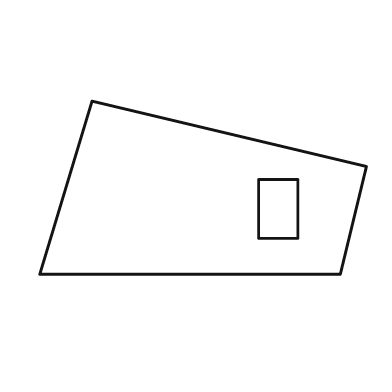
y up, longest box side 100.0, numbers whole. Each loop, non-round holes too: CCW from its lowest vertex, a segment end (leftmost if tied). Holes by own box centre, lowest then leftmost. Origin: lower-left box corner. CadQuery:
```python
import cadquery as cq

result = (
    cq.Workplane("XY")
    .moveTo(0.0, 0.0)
    .lineTo(92.0, 0.0)
    .lineTo(100.0, 33.0)
    .lineTo(16.0, 53.0)
    .close()
    .moveTo(67.0, 11.0)
    .lineTo(79.0, 11.0)
    .lineTo(79.0, 29.0)
    .lineTo(67.0, 29.0)
    .close()
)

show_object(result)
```